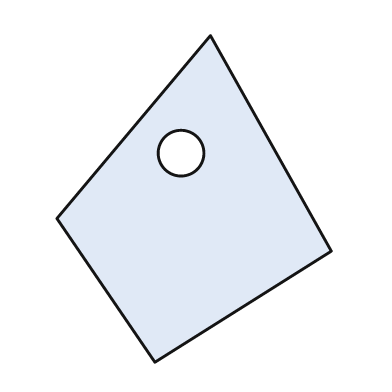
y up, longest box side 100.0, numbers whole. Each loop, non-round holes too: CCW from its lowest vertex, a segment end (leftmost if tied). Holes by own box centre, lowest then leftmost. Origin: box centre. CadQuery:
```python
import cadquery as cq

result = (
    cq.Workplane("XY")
    .moveTo(-12.0, -50.0)
    .lineTo(42.0, -16.0)
    .lineTo(5.0, 50.0)
    .lineTo(-42.0, -6.0)
    .close()
    .moveTo(-4.0, 14.0)
    .circle(7.0)
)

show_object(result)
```